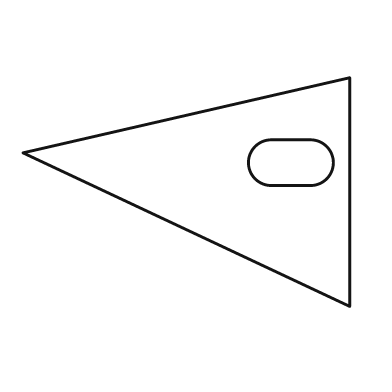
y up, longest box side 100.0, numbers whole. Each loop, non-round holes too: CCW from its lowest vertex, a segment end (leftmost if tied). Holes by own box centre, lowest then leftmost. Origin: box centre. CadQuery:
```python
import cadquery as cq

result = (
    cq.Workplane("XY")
    .moveTo(50.0, -35.0)
    .lineTo(50.0, 35.0)
    .lineTo(-50.0, 12.0)
    .close()
    .moveTo(26.0, 2.0)
    .lineTo(38.0, 2.0)
    .threePointArc((45.0, 9.0), (38.0, 16.0))
    .lineTo(26.0, 16.0)
    .threePointArc((19.0, 9.0), (26.0, 2.0))
    .close()
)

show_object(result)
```